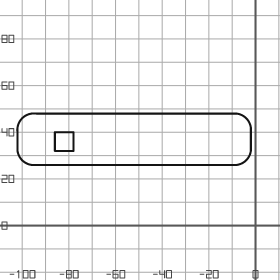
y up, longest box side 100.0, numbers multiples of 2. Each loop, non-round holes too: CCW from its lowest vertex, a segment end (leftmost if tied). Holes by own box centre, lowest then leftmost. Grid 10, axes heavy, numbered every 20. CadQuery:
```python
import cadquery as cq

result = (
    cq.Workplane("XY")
    .moveTo(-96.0, 26.0)
    .lineTo(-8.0, 26.0)
    .threePointArc((-4.0, 28.0), (-2.0, 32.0))
    .lineTo(-2.0, 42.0)
    .threePointArc((-4.0, 46.0), (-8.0, 48.0))
    .lineTo(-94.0, 48.0)
    .threePointArc((-100.0, 46.0), (-102.0, 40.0))
    .lineTo(-102.0, 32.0)
    .threePointArc((-100.0, 28.0), (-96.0, 26.0))
    .close()
    .moveTo(-86.0, 32.0)
    .lineTo(-78.0, 32.0)
    .lineTo(-78.0, 40.0)
    .lineTo(-86.0, 40.0)
    .close()
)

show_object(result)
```